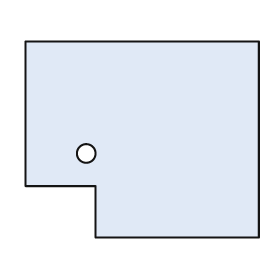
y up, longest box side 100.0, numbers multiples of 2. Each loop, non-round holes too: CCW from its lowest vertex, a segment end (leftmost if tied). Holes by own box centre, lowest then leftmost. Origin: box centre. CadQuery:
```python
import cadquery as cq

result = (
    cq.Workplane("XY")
    .moveTo(-20.0, -42.0)
    .lineTo(50.0, -42.0)
    .lineTo(50.0, 42.0)
    .lineTo(-50.0, 42.0)
    .lineTo(-50.0, -20.0)
    .lineTo(-20.0, -20.0)
    .close()
    .moveTo(-24.0, -6.0)
    .circle(4.0)
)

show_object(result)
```